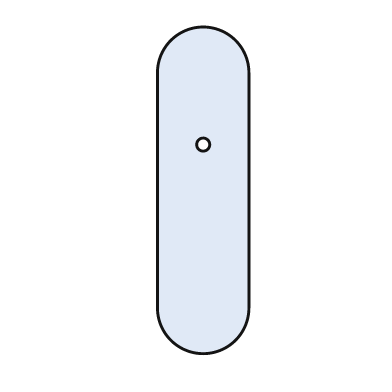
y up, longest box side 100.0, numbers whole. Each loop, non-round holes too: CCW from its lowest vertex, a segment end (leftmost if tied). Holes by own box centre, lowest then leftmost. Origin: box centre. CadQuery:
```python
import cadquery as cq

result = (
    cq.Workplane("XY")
    .moveTo(-14.0, -36.0)
    .threePointArc((0.0, -50.0), (14.0, -36.0))
    .lineTo(14.0, 36.0)
    .threePointArc((0.0, 50.0), (-14.0, 36.0))
    .close()
    .moveTo(0.0, 14.0)
    .circle(2.0)
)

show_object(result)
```